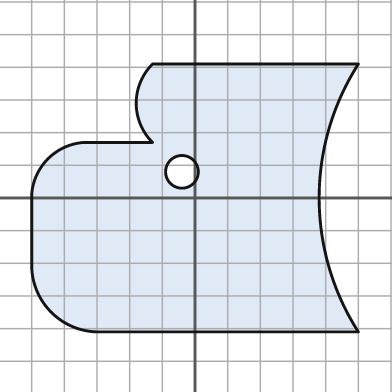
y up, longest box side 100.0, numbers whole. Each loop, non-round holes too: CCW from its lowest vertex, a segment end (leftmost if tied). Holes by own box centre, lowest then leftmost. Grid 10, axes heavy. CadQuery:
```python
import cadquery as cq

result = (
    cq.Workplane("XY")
    .moveTo(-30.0, -41.0)
    .lineTo(50.0, -41.0)
    .threePointArc((38.0, 0.0), (50.0, 41.0))
    .lineTo(-13.0, 41.0)
    .threePointArc((-18.0, 29.0), (-13.0, 17.0))
    .lineTo(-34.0, 17.0)
    .threePointArc((-45.0, 12.0), (-50.0, 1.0))
    .lineTo(-50.0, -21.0)
    .threePointArc((-44.0, -35.0), (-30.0, -41.0))
    .close()
    .moveTo(-4.0, 8.0)
    .circle(5.0)
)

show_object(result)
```